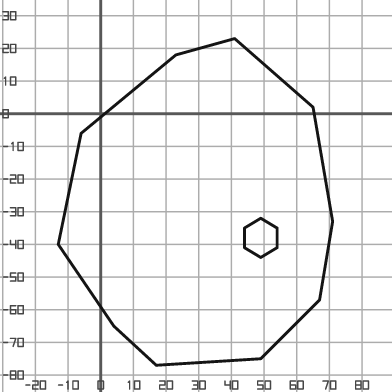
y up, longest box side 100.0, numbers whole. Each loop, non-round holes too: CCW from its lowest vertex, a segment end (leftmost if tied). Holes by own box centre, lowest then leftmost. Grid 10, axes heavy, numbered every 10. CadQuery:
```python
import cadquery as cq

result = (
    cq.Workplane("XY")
    .moveTo(17.0, -77.0)
    .lineTo(49.0, -75.0)
    .lineTo(67.0, -57.0)
    .lineTo(71.0, -33.0)
    .lineTo(65.0, 2.0)
    .lineTo(41.0, 23.0)
    .lineTo(23.0, 18.0)
    .lineTo(-6.0, -6.0)
    .lineTo(-13.0, -40.0)
    .lineTo(4.0, -65.0)
    .close()
    .moveTo(49.0, -44.0)
    .lineTo(54.0, -41.0)
    .lineTo(54.0, -35.0)
    .lineTo(49.0, -32.0)
    .lineTo(44.0, -35.0)
    .lineTo(44.0, -41.0)
    .close()
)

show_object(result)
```